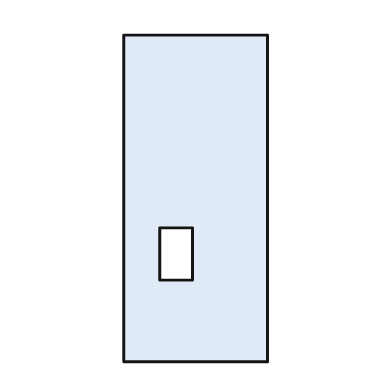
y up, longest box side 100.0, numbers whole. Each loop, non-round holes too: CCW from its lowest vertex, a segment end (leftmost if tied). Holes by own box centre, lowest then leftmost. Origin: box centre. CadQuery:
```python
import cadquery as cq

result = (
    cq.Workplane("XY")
    .moveTo(-22.0, -50.0)
    .lineTo(22.0, -50.0)
    .lineTo(22.0, 50.0)
    .lineTo(-22.0, 50.0)
    .close()
    .moveTo(-11.0, -25.0)
    .lineTo(-1.0, -25.0)
    .lineTo(-1.0, -9.0)
    .lineTo(-11.0, -9.0)
    .close()
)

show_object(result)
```